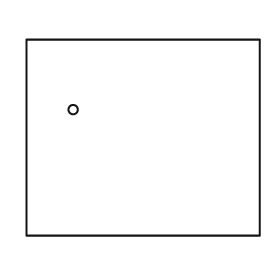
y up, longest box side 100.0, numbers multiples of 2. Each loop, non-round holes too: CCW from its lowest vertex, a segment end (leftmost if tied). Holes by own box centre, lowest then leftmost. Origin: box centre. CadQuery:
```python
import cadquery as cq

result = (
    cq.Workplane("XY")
    .moveTo(-50.0, -42.0)
    .lineTo(50.0, -42.0)
    .lineTo(50.0, 42.0)
    .lineTo(-50.0, 42.0)
    .close()
    .moveTo(-30.0, 12.0)
    .circle(2.0)
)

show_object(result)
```